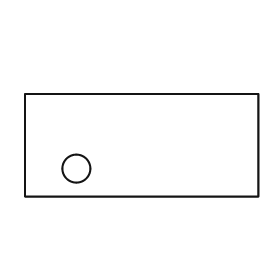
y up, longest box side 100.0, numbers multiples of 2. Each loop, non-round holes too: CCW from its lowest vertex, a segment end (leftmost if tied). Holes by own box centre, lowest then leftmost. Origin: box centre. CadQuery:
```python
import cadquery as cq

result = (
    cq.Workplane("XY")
    .moveTo(-50.0, -22.0)
    .lineTo(50.0, -22.0)
    .lineTo(50.0, 22.0)
    .lineTo(-50.0, 22.0)
    .close()
    .moveTo(-28.0, -10.0)
    .circle(6.0)
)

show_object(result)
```